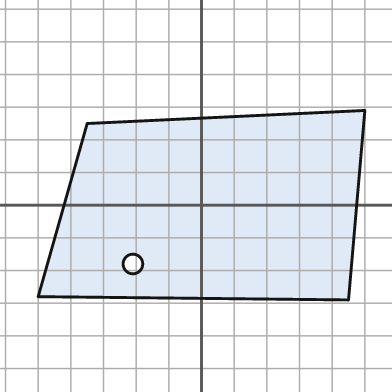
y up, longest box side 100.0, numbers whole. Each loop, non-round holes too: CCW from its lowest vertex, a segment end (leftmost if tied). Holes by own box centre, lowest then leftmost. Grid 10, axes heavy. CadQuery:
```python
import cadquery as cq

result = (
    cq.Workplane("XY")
    .moveTo(45.0, -29.0)
    .lineTo(50.0, 29.0)
    .lineTo(-35.0, 25.0)
    .lineTo(-50.0, -28.0)
    .close()
    .moveTo(-21.0, -18.0)
    .circle(3.0)
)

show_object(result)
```